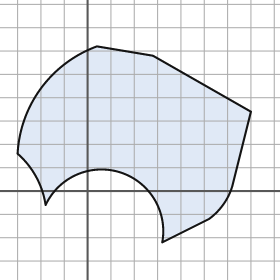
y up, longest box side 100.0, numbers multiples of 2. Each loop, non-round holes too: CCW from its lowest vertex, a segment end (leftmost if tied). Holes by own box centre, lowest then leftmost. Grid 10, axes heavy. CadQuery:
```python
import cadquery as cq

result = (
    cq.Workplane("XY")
    .moveTo(32.0, -22.0)
    .lineTo(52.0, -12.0)
    .threePointArc((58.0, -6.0), (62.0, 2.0))
    .lineTo(70.0, 34.0)
    .lineTo(28.0, 58.0)
    .lineTo(4.0, 62.0)
    .threePointArc((-20.0, 44.0), (-30.0, 16.0))
    .threePointArc((-22.0, 6.0), (-18.0, -6.0))
    .threePointArc((14.0, 8.0), (32.0, -22.0))
    .close()
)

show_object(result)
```